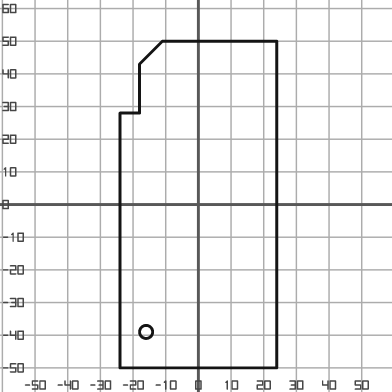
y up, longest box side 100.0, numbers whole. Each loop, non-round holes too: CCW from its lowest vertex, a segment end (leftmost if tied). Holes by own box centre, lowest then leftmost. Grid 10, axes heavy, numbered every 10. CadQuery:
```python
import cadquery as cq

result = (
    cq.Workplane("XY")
    .moveTo(-24.0, -50.0)
    .lineTo(24.0, -50.0)
    .lineTo(24.0, 50.0)
    .lineTo(-11.0, 50.0)
    .lineTo(-18.0, 43.0)
    .lineTo(-18.0, 28.0)
    .lineTo(-24.0, 28.0)
    .close()
    .moveTo(-16.0, -39.0)
    .circle(2.0)
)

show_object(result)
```